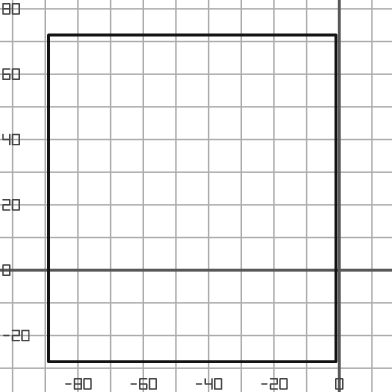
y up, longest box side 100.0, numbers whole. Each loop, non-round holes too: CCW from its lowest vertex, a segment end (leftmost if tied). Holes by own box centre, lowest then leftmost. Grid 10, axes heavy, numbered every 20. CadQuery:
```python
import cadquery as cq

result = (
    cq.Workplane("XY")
    .moveTo(-89.0, -28.0)
    .lineTo(-1.0, -28.0)
    .lineTo(-1.0, 72.0)
    .lineTo(-89.0, 72.0)
    .close()
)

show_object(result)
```